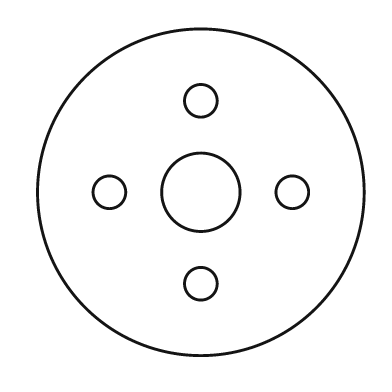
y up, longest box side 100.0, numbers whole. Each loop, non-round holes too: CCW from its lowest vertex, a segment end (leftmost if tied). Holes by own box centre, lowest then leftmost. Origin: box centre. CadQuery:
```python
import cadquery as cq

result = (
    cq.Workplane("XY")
    .moveTo(0.0, 0.0)
    .circle(50.0)
    .moveTo(0.0, -28.0)
    .circle(5.0)
    .moveTo(-28.0, 0.0)
    .circle(5.0)
    .moveTo(0.0, 0.0)
    .circle(12.0)
    .moveTo(28.0, 0.0)
    .circle(5.0)
    .moveTo(0.0, 28.0)
    .circle(5.0)
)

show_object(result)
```